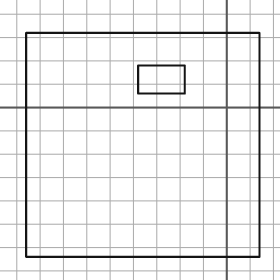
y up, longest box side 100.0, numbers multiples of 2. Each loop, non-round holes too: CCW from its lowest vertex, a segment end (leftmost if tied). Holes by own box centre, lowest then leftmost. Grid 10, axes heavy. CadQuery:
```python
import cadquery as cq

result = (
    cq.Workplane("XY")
    .moveTo(-86.0, -64.0)
    .lineTo(14.0, -64.0)
    .lineTo(14.0, 32.0)
    .lineTo(-86.0, 32.0)
    .close()
    .moveTo(-38.0, 6.0)
    .lineTo(-18.0, 6.0)
    .lineTo(-18.0, 18.0)
    .lineTo(-38.0, 18.0)
    .close()
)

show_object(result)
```